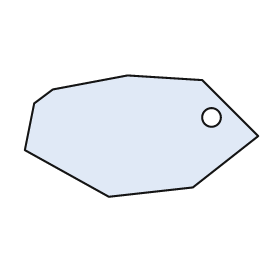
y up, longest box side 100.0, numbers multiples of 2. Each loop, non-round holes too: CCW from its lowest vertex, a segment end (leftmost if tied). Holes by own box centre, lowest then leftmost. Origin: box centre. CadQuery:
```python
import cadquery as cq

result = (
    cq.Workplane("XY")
    .moveTo(-14.0, -26.0)
    .lineTo(22.0, -22.0)
    .lineTo(50.0, 0.0)
    .lineTo(26.0, 24.0)
    .lineTo(-6.0, 26.0)
    .lineTo(-38.0, 20.0)
    .lineTo(-46.0, 14.0)
    .lineTo(-50.0, -6.0)
    .close()
    .moveTo(30.0, 8.0)
    .circle(4.0)
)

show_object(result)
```